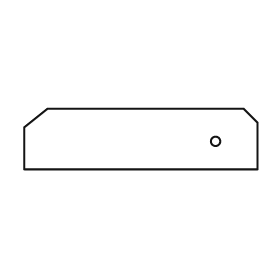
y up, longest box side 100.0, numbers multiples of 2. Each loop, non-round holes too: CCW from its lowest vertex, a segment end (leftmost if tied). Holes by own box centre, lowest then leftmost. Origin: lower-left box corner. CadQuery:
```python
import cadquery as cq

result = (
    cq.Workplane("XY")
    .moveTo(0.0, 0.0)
    .lineTo(100.0, 0.0)
    .lineTo(100.0, 20.0)
    .lineTo(94.0, 26.0)
    .lineTo(10.0, 26.0)
    .lineTo(0.0, 18.0)
    .close()
    .moveTo(82.0, 12.0)
    .circle(2.0)
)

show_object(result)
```